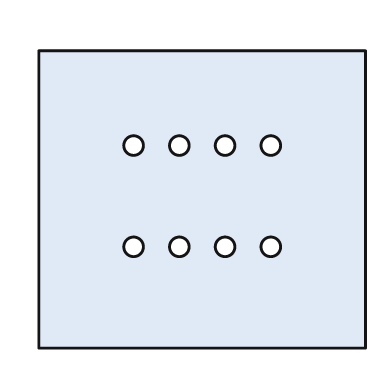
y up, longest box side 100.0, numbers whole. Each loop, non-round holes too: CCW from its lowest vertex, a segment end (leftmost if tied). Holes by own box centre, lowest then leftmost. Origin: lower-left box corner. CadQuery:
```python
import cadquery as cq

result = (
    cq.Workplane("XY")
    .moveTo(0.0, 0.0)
    .lineTo(100.0, 0.0)
    .lineTo(100.0, 91.0)
    .lineTo(0.0, 91.0)
    .close()
    .moveTo(29.0, 31.0)
    .circle(3.0)
    .moveTo(43.0, 31.0)
    .circle(3.0)
    .moveTo(57.0, 31.0)
    .circle(3.0)
    .moveTo(71.0, 31.0)
    .circle(3.0)
    .moveTo(29.0, 62.0)
    .circle(3.0)
    .moveTo(43.0, 62.0)
    .circle(3.0)
    .moveTo(57.0, 62.0)
    .circle(3.0)
    .moveTo(71.0, 62.0)
    .circle(3.0)
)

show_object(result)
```